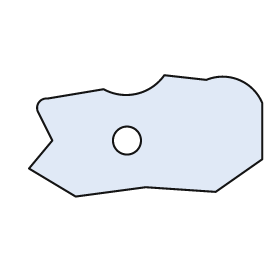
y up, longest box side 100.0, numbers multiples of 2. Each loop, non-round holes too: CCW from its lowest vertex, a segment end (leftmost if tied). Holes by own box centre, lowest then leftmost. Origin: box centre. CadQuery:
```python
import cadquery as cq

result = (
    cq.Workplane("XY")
    .moveTo(-30.0, -26.0)
    .lineTo(0.0, -22.0)
    .lineTo(30.0, -24.0)
    .lineTo(50.0, -10.0)
    .lineTo(50.0, 14.0)
    .threePointArc((40.0, 24.0), (26.0, 24.0))
    .lineTo(8.0, 26.0)
    .threePointArc((-4.0, 18.0), (-18.0, 20.0))
    .lineTo(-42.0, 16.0)
    .threePointArc((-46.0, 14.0), (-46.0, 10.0))
    .lineTo(-40.0, -2.0)
    .lineTo(-50.0, -14.0)
    .close()
    .moveTo(-8.0, -2.0)
    .circle(6.0)
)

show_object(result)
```